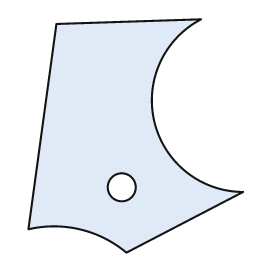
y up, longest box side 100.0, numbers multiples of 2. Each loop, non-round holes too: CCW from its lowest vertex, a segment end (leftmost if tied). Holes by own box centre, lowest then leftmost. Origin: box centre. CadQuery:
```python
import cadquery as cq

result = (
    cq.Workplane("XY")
    .moveTo(-4.0, -50.0)
    .lineTo(46.0, -24.0)
    .threePointArc((8.0, 6.0), (28.0, 50.0))
    .lineTo(-34.0, 48.0)
    .lineTo(-46.0, -40.0)
    .threePointArc((-24.0, -40.0), (-4.0, -50.0))
    .close()
    .moveTo(-6.0, -22.0)
    .circle(6.0)
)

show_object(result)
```